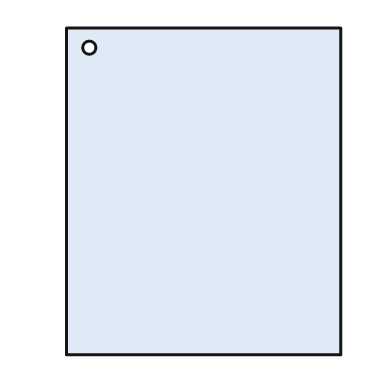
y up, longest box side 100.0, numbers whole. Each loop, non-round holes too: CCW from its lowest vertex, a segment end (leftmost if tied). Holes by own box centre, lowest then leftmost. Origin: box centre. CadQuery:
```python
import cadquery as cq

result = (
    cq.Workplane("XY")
    .moveTo(-42.0, -50.0)
    .lineTo(42.0, -50.0)
    .lineTo(42.0, 50.0)
    .lineTo(-42.0, 50.0)
    .close()
    .moveTo(-35.0, 44.0)
    .circle(2.0)
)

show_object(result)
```